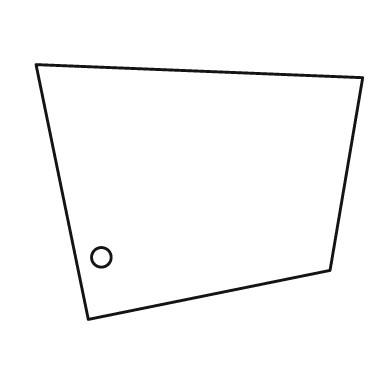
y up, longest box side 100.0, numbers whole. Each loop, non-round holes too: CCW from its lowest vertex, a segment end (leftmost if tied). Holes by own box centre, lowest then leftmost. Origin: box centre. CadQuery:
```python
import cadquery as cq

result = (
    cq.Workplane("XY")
    .moveTo(-34.0, -39.0)
    .lineTo(40.0, -24.0)
    .lineTo(50.0, 35.0)
    .lineTo(-50.0, 39.0)
    .close()
    .moveTo(-30.0, -20.0)
    .circle(3.0)
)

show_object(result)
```